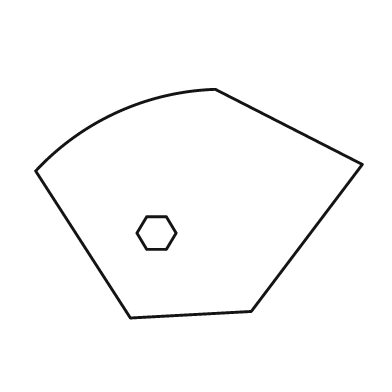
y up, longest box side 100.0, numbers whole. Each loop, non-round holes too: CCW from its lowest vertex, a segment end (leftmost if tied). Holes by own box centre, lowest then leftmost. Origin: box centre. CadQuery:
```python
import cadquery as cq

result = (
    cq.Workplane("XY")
    .moveTo(-21.0, -35.0)
    .lineTo(16.0, -33.0)
    .lineTo(50.0, 12.0)
    .lineTo(5.0, 35.0)
    .threePointArc((-25.0, 28.0), (-50.0, 10.0))
    .close()
    .moveTo(-16.0, -14.0)
    .lineTo(-10.0, -14.0)
    .lineTo(-7.0, -9.0)
    .lineTo(-10.0, -4.0)
    .lineTo(-16.0, -4.0)
    .lineTo(-19.0, -9.0)
    .close()
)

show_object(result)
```